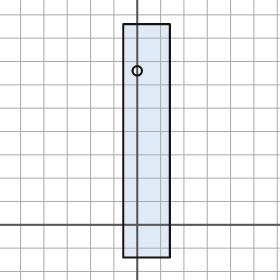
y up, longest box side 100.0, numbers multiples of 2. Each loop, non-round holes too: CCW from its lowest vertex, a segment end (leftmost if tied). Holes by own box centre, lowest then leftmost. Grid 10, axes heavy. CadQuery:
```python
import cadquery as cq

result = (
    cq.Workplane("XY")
    .moveTo(-6.0, -14.0)
    .lineTo(14.0, -14.0)
    .lineTo(14.0, 86.0)
    .lineTo(-6.0, 86.0)
    .close()
    .moveTo(0.0, 66.0)
    .circle(2.0)
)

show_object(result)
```